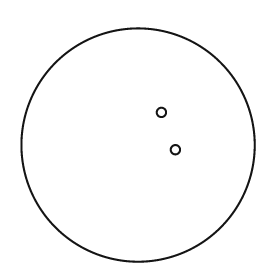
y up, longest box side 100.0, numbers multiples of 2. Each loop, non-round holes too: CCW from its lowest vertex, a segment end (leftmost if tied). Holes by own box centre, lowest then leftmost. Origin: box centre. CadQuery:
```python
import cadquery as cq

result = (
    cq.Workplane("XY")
    .moveTo(0.0, 0.0)
    .circle(50.0)
    .moveTo(16.0, -2.0)
    .circle(2.0)
    .moveTo(10.0, 14.0)
    .circle(2.0)
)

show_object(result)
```